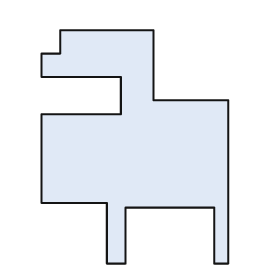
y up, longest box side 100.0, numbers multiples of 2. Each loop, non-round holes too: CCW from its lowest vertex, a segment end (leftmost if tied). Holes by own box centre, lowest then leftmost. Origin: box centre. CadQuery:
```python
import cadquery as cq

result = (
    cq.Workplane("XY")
    .moveTo(-12.0, -50.0)
    .lineTo(-4.0, -50.0)
    .lineTo(-4.0, -26.0)
    .lineTo(34.0, -26.0)
    .lineTo(34.0, -50.0)
    .lineTo(40.0, -50.0)
    .lineTo(40.0, 20.0)
    .lineTo(8.0, 20.0)
    .lineTo(8.0, 50.0)
    .lineTo(-32.0, 50.0)
    .lineTo(-32.0, 40.0)
    .lineTo(-40.0, 40.0)
    .lineTo(-40.0, 30.0)
    .lineTo(-6.0, 30.0)
    .lineTo(-6.0, 14.0)
    .lineTo(-40.0, 14.0)
    .lineTo(-40.0, -24.0)
    .lineTo(-12.0, -24.0)
    .close()
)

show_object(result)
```